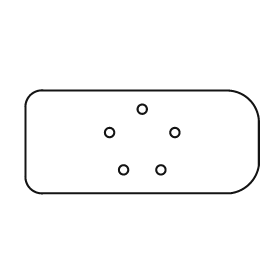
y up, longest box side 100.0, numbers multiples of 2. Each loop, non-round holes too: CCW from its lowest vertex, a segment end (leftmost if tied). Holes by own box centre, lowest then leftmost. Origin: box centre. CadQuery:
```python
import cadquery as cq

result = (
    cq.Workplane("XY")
    .moveTo(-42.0, -22.0)
    .lineTo(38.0, -22.0)
    .threePointArc((46.0, -18.0), (50.0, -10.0))
    .lineTo(50.0, 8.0)
    .threePointArc((46.0, 18.0), (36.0, 22.0))
    .lineTo(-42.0, 22.0)
    .threePointArc((-48.0, 20.0), (-50.0, 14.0))
    .lineTo(-50.0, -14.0)
    .threePointArc((-48.0, -20.0), (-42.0, -22.0))
    .close()
    .moveTo(-8.0, -12.0)
    .circle(2.0)
    .moveTo(8.0, -12.0)
    .circle(2.0)
    .moveTo(-14.0, 4.0)
    .circle(2.0)
    .moveTo(14.0, 4.0)
    .circle(2.0)
    .moveTo(0.0, 14.0)
    .circle(2.0)
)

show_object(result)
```